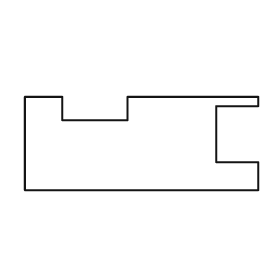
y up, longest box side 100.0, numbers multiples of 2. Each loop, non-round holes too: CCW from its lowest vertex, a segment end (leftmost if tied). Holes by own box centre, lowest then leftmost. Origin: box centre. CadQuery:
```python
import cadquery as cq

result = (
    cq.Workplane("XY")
    .moveTo(-50.0, -20.0)
    .lineTo(50.0, -20.0)
    .lineTo(50.0, -8.0)
    .lineTo(32.0, -8.0)
    .lineTo(32.0, 16.0)
    .lineTo(50.0, 16.0)
    .lineTo(50.0, 20.0)
    .lineTo(-6.0, 20.0)
    .lineTo(-6.0, 10.0)
    .lineTo(-34.0, 10.0)
    .lineTo(-34.0, 20.0)
    .lineTo(-50.0, 20.0)
    .close()
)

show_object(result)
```